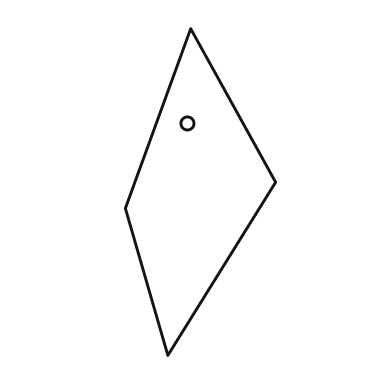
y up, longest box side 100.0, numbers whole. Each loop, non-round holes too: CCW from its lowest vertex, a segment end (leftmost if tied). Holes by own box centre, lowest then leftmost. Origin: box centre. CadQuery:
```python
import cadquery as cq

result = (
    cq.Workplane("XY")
    .moveTo(-10.0, -50.0)
    .lineTo(23.0, 3.0)
    .lineTo(-3.0, 50.0)
    .lineTo(-23.0, -5.0)
    .close()
    .moveTo(-4.0, 21.0)
    .circle(2.0)
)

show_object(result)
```